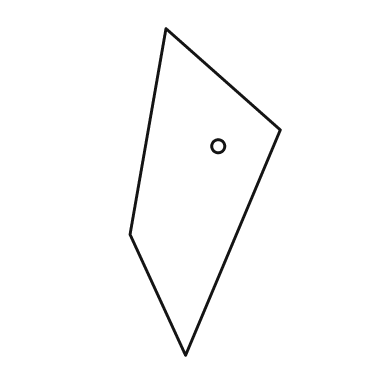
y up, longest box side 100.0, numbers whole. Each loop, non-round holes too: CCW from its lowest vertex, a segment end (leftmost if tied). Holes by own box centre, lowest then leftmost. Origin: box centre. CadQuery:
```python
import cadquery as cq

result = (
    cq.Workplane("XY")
    .moveTo(-6.0, -50.0)
    .lineTo(23.0, 19.0)
    .lineTo(-12.0, 50.0)
    .lineTo(-23.0, -13.0)
    .close()
    .moveTo(4.0, 14.0)
    .circle(2.0)
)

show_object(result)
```